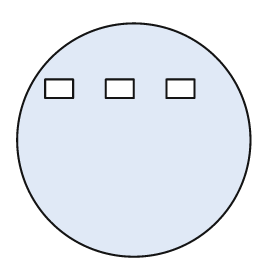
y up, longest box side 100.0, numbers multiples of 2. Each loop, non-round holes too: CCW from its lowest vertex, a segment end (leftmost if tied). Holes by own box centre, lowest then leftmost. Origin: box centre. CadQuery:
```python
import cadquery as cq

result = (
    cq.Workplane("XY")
    .moveTo(0.0, 0.0)
    .circle(50.0)
    .moveTo(-38.0, 18.0)
    .lineTo(-26.0, 18.0)
    .lineTo(-26.0, 26.0)
    .lineTo(-38.0, 26.0)
    .close()
    .moveTo(-12.0, 18.0)
    .lineTo(0.0, 18.0)
    .lineTo(0.0, 26.0)
    .lineTo(-12.0, 26.0)
    .close()
    .moveTo(14.0, 18.0)
    .lineTo(26.0, 18.0)
    .lineTo(26.0, 26.0)
    .lineTo(14.0, 26.0)
    .close()
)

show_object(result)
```